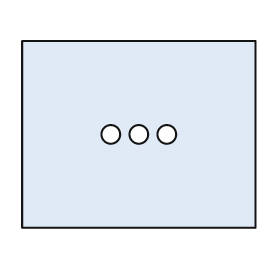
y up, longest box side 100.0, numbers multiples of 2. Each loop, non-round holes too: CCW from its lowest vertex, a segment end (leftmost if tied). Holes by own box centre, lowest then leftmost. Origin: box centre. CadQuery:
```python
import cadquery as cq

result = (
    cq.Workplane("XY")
    .moveTo(-50.0, -40.0)
    .lineTo(50.0, -40.0)
    .lineTo(50.0, 40.0)
    .lineTo(-50.0, 40.0)
    .close()
    .moveTo(-12.0, 0.0)
    .circle(4.0)
    .moveTo(0.0, 0.0)
    .circle(4.0)
    .moveTo(12.0, 0.0)
    .circle(4.0)
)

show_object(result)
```